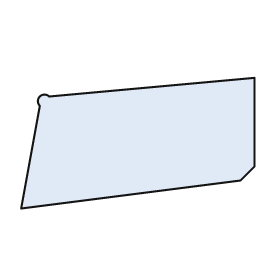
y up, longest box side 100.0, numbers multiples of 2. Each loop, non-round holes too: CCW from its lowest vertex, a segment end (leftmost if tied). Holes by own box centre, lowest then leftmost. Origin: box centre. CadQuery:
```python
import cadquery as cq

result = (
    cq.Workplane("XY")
    .moveTo(-50.0, -28.0)
    .lineTo(44.0, -16.0)
    .lineTo(50.0, -10.0)
    .lineTo(50.0, 28.0)
    .lineTo(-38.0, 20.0)
    .threePointArc((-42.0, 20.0), (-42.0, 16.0))
    .close()
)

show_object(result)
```